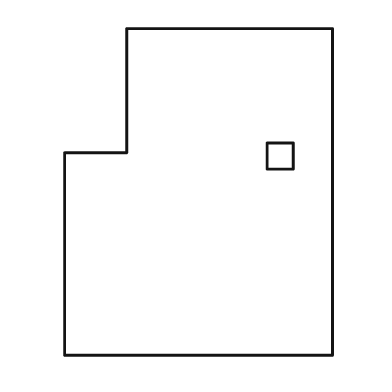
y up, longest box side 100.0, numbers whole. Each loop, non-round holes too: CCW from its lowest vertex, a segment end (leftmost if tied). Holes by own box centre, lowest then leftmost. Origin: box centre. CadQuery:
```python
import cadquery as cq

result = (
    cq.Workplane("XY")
    .moveTo(-41.0, -50.0)
    .lineTo(41.0, -50.0)
    .lineTo(41.0, 50.0)
    .lineTo(-22.0, 50.0)
    .lineTo(-22.0, 12.0)
    .lineTo(-41.0, 12.0)
    .close()
    .moveTo(21.0, 7.0)
    .lineTo(29.0, 7.0)
    .lineTo(29.0, 15.0)
    .lineTo(21.0, 15.0)
    .close()
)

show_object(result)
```